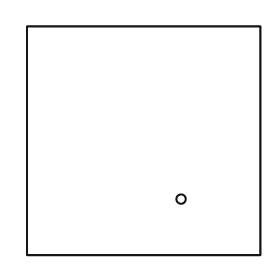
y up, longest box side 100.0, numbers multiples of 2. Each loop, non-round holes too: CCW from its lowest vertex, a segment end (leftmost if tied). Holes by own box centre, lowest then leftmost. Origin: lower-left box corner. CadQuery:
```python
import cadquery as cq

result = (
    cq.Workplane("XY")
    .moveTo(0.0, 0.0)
    .lineTo(100.0, 0.0)
    .lineTo(100.0, 98.0)
    .lineTo(0.0, 98.0)
    .close()
    .moveTo(66.0, 24.0)
    .circle(2.0)
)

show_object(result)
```